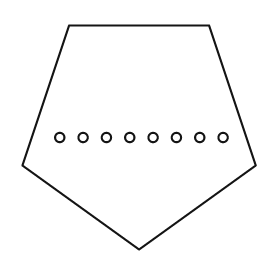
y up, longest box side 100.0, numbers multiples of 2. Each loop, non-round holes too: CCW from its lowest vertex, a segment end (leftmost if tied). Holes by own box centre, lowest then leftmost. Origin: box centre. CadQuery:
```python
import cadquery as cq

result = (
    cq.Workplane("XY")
    .moveTo(0.0, -48.0)
    .lineTo(50.0, -12.0)
    .lineTo(30.0, 48.0)
    .lineTo(-30.0, 48.0)
    .lineTo(-50.0, -12.0)
    .close()
    .moveTo(-34.0, 0.0)
    .circle(2.0)
    .moveTo(-24.0, 0.0)
    .circle(2.0)
    .moveTo(-14.0, 0.0)
    .circle(2.0)
    .moveTo(-4.0, 0.0)
    .circle(2.0)
    .moveTo(6.0, 0.0)
    .circle(2.0)
    .moveTo(16.0, 0.0)
    .circle(2.0)
    .moveTo(26.0, 0.0)
    .circle(2.0)
    .moveTo(36.0, 0.0)
    .circle(2.0)
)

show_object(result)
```